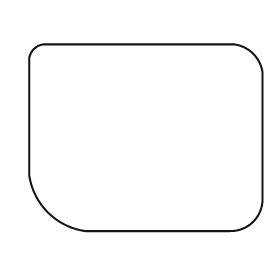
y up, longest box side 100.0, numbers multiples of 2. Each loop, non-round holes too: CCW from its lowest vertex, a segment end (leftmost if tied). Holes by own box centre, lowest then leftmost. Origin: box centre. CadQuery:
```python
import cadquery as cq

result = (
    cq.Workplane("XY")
    .moveTo(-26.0, -40.0)
    .lineTo(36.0, -40.0)
    .threePointArc((46.0, -36.0), (50.0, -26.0))
    .lineTo(50.0, 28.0)
    .threePointArc((46.0, 36.0), (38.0, 40.0))
    .lineTo(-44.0, 40.0)
    .threePointArc((-48.0, 38.0), (-50.0, 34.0))
    .lineTo(-50.0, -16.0)
    .threePointArc((-42.0, -32.0), (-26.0, -40.0))
    .close()
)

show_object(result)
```